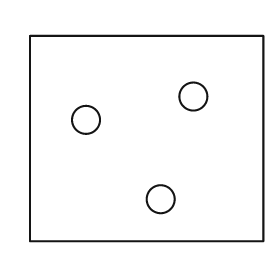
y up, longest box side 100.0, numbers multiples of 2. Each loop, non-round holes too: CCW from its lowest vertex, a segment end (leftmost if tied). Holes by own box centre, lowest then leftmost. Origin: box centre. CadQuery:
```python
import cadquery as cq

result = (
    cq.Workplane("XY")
    .moveTo(-50.0, -44.0)
    .lineTo(50.0, -44.0)
    .lineTo(50.0, 44.0)
    .lineTo(-50.0, 44.0)
    .close()
    .moveTo(6.0, -26.0)
    .circle(6.0)
    .moveTo(-26.0, 8.0)
    .circle(6.0)
    .moveTo(20.0, 18.0)
    .circle(6.0)
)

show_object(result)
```